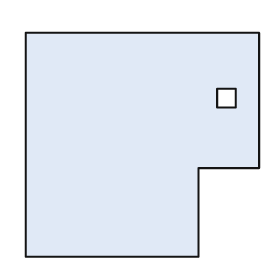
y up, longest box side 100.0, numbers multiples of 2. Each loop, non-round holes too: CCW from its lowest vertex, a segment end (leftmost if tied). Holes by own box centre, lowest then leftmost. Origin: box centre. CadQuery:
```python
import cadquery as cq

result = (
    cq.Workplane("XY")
    .moveTo(-50.0, -48.0)
    .lineTo(24.0, -48.0)
    .lineTo(24.0, -10.0)
    .lineTo(50.0, -10.0)
    .lineTo(50.0, 48.0)
    .lineTo(-50.0, 48.0)
    .close()
    .moveTo(32.0, 16.0)
    .lineTo(40.0, 16.0)
    .lineTo(40.0, 24.0)
    .lineTo(32.0, 24.0)
    .close()
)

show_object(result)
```